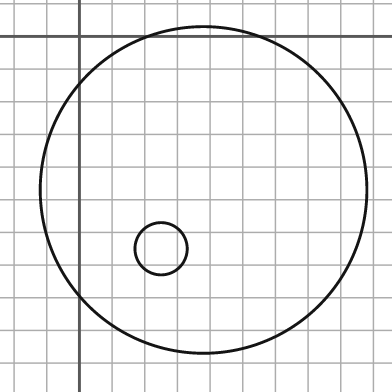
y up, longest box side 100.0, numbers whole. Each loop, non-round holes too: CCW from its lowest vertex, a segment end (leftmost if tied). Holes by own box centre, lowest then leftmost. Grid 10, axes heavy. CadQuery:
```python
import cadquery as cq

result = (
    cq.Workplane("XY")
    .moveTo(38.0, -47.0)
    .circle(50.0)
    .moveTo(25.0, -65.0)
    .circle(8.0)
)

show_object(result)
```